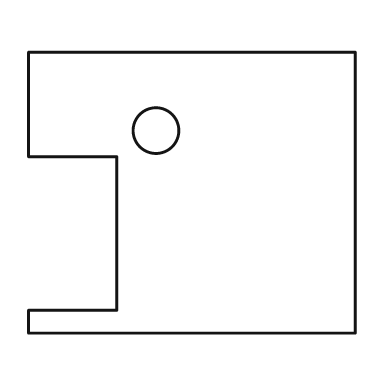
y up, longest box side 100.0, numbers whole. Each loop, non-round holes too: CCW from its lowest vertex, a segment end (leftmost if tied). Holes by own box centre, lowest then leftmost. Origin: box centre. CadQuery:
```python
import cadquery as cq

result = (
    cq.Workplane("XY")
    .moveTo(-50.0, -43.0)
    .lineTo(50.0, -43.0)
    .lineTo(50.0, 43.0)
    .lineTo(-50.0, 43.0)
    .lineTo(-50.0, 11.0)
    .lineTo(-23.0, 11.0)
    .lineTo(-23.0, -36.0)
    .lineTo(-50.0, -36.0)
    .close()
    .moveTo(-11.0, 19.0)
    .circle(7.0)
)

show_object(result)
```